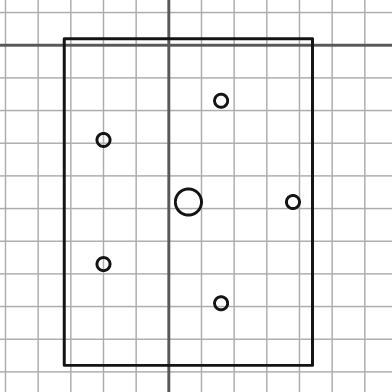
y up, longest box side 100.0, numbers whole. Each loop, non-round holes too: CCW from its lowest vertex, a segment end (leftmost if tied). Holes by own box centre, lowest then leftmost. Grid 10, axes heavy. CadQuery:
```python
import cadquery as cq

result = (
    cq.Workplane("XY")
    .moveTo(-32.0, -98.0)
    .lineTo(44.0, -98.0)
    .lineTo(44.0, 2.0)
    .lineTo(-32.0, 2.0)
    .close()
    .moveTo(16.0, -79.0)
    .circle(2.0)
    .moveTo(-20.0, -67.0)
    .circle(2.0)
    .moveTo(6.0, -48.0)
    .circle(4.0)
    .moveTo(38.0, -48.0)
    .circle(2.0)
    .moveTo(-20.0, -29.0)
    .circle(2.0)
    .moveTo(16.0, -17.0)
    .circle(2.0)
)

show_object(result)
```